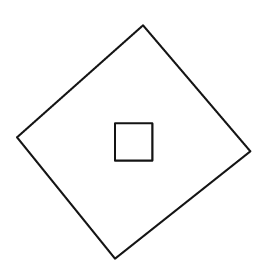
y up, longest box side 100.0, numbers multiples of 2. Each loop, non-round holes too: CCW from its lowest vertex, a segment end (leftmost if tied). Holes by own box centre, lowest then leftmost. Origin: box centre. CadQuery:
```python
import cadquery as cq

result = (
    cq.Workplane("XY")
    .moveTo(-8.0, -50.0)
    .lineTo(50.0, -4.0)
    .lineTo(4.0, 50.0)
    .lineTo(-50.0, 2.0)
    .close()
    .moveTo(-8.0, -8.0)
    .lineTo(8.0, -8.0)
    .lineTo(8.0, 8.0)
    .lineTo(-8.0, 8.0)
    .close()
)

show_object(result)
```